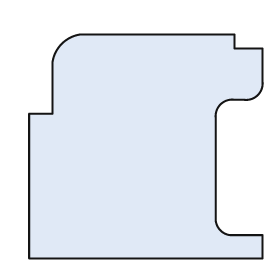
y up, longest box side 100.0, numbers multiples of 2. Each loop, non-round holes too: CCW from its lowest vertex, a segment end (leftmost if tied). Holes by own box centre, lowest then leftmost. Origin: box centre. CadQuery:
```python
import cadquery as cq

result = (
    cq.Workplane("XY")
    .moveTo(-50.0, -48.0)
    .lineTo(50.0, -48.0)
    .lineTo(50.0, -38.0)
    .lineTo(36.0, -38.0)
    .threePointArc((32.0, -36.0), (30.0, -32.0))
    .lineTo(30.0, 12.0)
    .threePointArc((32.0, 18.0), (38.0, 20.0))
    .lineTo(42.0, 20.0)
    .threePointArc((48.0, 22.0), (50.0, 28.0))
    .lineTo(50.0, 42.0)
    .lineTo(38.0, 42.0)
    .lineTo(38.0, 48.0)
    .lineTo(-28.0, 48.0)
    .threePointArc((-36.0, 44.0), (-40.0, 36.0))
    .lineTo(-40.0, 14.0)
    .lineTo(-50.0, 14.0)
    .close()
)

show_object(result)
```